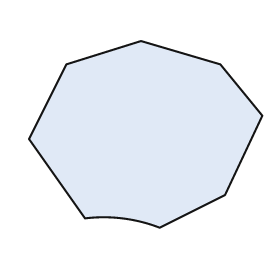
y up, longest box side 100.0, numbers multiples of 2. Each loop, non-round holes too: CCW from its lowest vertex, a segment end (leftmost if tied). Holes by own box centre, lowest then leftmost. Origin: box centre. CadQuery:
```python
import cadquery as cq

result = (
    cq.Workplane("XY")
    .moveTo(6.0, -40.0)
    .lineTo(34.0, -26.0)
    .lineTo(50.0, 8.0)
    .lineTo(32.0, 30.0)
    .lineTo(-2.0, 40.0)
    .lineTo(-34.0, 30.0)
    .lineTo(-50.0, -2.0)
    .lineTo(-26.0, -36.0)
    .threePointArc((-10.0, -36.0), (6.0, -40.0))
    .close()
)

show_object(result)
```